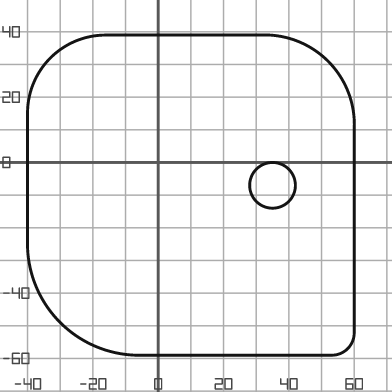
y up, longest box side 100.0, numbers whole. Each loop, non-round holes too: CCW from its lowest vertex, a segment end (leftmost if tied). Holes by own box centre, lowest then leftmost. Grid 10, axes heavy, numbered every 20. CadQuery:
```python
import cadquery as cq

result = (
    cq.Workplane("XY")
    .moveTo(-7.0, -59.0)
    .lineTo(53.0, -59.0)
    .threePointArc((58.0, -57.0), (60.0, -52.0))
    .lineTo(60.0, 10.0)
    .threePointArc((52.0, 31.0), (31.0, 39.0))
    .lineTo(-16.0, 39.0)
    .threePointArc((-33.0, 32.0), (-40.0, 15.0))
    .lineTo(-40.0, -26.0)
    .threePointArc((-30.0, -49.0), (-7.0, -59.0))
    .close()
    .moveTo(35.0, -7.0)
    .circle(7.0)
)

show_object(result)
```